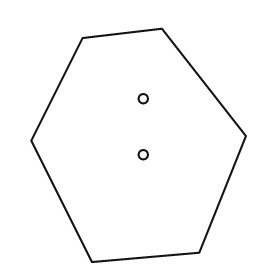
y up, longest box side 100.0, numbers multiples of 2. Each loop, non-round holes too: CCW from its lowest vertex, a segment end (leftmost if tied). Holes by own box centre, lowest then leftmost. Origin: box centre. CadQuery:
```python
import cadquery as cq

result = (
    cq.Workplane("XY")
    .moveTo(-20.0, -50.0)
    .lineTo(26.0, -46.0)
    .lineTo(46.0, 4.0)
    .lineTo(10.0, 50.0)
    .lineTo(-24.0, 46.0)
    .lineTo(-46.0, 2.0)
    .close()
    .moveTo(2.0, -4.0)
    .circle(2.0)
    .moveTo(2.0, 20.0)
    .circle(2.0)
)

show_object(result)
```